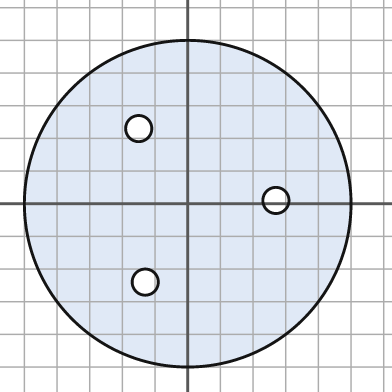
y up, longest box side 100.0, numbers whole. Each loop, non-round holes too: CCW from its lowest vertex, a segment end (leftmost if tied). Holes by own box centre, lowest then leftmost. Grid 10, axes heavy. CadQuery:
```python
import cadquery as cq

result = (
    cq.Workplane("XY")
    .moveTo(0.0, 0.0)
    .circle(50.0)
    .moveTo(-13.0, -24.0)
    .circle(4.0)
    .moveTo(27.0, 1.0)
    .circle(4.0)
    .moveTo(-15.0, 23.0)
    .circle(4.0)
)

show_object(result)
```